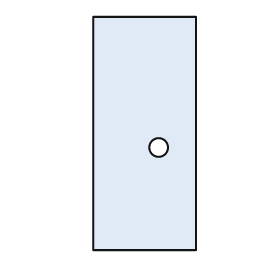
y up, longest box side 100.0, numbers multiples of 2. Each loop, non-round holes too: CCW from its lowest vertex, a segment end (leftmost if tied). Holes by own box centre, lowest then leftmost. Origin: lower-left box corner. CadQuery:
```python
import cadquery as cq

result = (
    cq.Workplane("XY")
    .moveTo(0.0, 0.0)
    .lineTo(44.0, 0.0)
    .lineTo(44.0, 100.0)
    .lineTo(0.0, 100.0)
    .close()
    .moveTo(28.0, 44.0)
    .circle(4.0)
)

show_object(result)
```